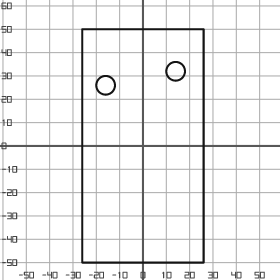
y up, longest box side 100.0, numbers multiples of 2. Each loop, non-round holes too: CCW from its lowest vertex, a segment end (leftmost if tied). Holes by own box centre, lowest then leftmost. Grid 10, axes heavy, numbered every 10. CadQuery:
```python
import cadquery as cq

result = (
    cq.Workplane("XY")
    .moveTo(-26.0, -50.0)
    .lineTo(26.0, -50.0)
    .lineTo(26.0, 50.0)
    .lineTo(-26.0, 50.0)
    .close()
    .moveTo(-16.0, 26.0)
    .circle(4.0)
    .moveTo(14.0, 32.0)
    .circle(4.0)
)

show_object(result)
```